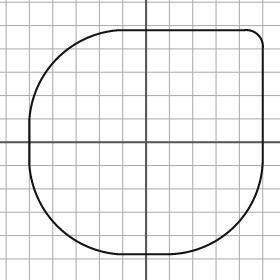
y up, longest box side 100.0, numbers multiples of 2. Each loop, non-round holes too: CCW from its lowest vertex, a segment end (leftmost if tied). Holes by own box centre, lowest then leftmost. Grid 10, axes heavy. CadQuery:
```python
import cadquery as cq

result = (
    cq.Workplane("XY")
    .moveTo(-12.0, -48.0)
    .lineTo(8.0, -48.0)
    .threePointArc((38.0, -36.0), (50.0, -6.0))
    .lineTo(50.0, 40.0)
    .threePointArc((48.0, 46.0), (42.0, 48.0))
    .lineTo(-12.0, 48.0)
    .threePointArc((-38.0, 36.0), (-50.0, 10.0))
    .lineTo(-50.0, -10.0)
    .threePointArc((-38.0, -36.0), (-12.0, -48.0))
    .close()
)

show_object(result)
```